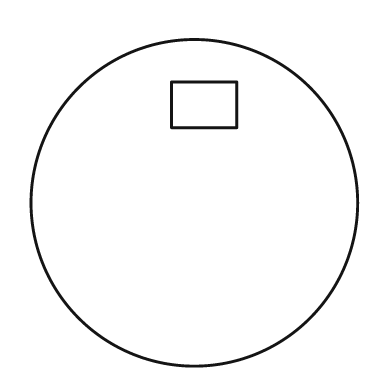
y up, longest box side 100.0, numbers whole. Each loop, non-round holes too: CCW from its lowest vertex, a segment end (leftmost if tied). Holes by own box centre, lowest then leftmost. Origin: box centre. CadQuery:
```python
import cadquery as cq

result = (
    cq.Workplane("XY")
    .moveTo(0.0, 0.0)
    .circle(50.0)
    .moveTo(-7.0, 23.0)
    .lineTo(13.0, 23.0)
    .lineTo(13.0, 37.0)
    .lineTo(-7.0, 37.0)
    .close()
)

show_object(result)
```